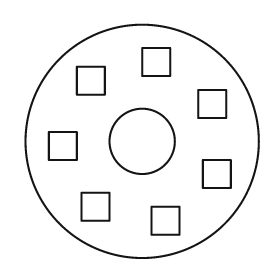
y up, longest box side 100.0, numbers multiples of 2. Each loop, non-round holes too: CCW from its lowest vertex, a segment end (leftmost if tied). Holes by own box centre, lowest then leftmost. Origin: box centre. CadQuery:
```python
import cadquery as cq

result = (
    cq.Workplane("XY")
    .moveTo(0.0, 0.0)
    .circle(50.0)
    .moveTo(4.0, -40.0)
    .lineTo(16.0, -40.0)
    .lineTo(16.0, -28.0)
    .lineTo(4.0, -28.0)
    .close()
    .moveTo(-26.0, -34.0)
    .lineTo(-14.0, -34.0)
    .lineTo(-14.0, -22.0)
    .lineTo(-26.0, -22.0)
    .close()
    .moveTo(26.0, -20.0)
    .lineTo(38.0, -20.0)
    .lineTo(38.0, -8.0)
    .lineTo(26.0, -8.0)
    .close()
    .moveTo(-40.0, -8.0)
    .lineTo(-28.0, -8.0)
    .lineTo(-28.0, 4.0)
    .lineTo(-40.0, 4.0)
    .close()
    .moveTo(0.0, 0.0)
    .circle(14.0)
    .moveTo(24.0, 10.0)
    .lineTo(36.0, 10.0)
    .lineTo(36.0, 22.0)
    .lineTo(24.0, 22.0)
    .close()
    .moveTo(-28.0, 20.0)
    .lineTo(-16.0, 20.0)
    .lineTo(-16.0, 32.0)
    .lineTo(-28.0, 32.0)
    .close()
    .moveTo(0.0, 28.0)
    .lineTo(12.0, 28.0)
    .lineTo(12.0, 40.0)
    .lineTo(0.0, 40.0)
    .close()
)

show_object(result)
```